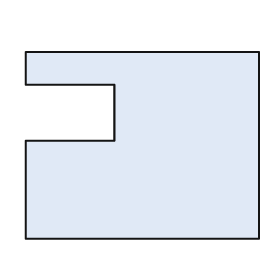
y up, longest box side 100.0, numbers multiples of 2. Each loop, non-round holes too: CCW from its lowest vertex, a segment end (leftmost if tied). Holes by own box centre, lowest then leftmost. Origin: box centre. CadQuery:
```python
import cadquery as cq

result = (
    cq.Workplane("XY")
    .moveTo(-50.0, -40.0)
    .lineTo(50.0, -40.0)
    .lineTo(50.0, 40.0)
    .lineTo(-50.0, 40.0)
    .lineTo(-50.0, 26.0)
    .lineTo(-12.0, 26.0)
    .lineTo(-12.0, 2.0)
    .lineTo(-50.0, 2.0)
    .close()
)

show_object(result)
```